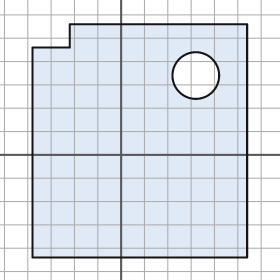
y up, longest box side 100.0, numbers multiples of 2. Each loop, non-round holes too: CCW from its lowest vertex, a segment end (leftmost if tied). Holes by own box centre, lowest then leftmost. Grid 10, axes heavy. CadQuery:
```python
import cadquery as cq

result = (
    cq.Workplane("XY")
    .moveTo(-38.0, -44.0)
    .lineTo(54.0, -44.0)
    .lineTo(54.0, 56.0)
    .lineTo(-22.0, 56.0)
    .lineTo(-22.0, 46.0)
    .lineTo(-38.0, 46.0)
    .close()
    .moveTo(32.0, 34.0)
    .circle(10.0)
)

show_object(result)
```